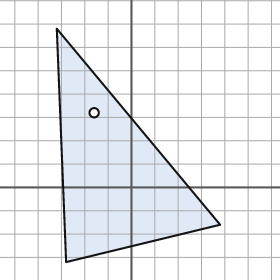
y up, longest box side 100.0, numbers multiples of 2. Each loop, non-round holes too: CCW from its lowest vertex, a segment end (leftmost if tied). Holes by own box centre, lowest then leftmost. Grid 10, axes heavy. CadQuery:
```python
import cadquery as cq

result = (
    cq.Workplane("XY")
    .moveTo(-28.0, -32.0)
    .lineTo(38.0, -16.0)
    .lineTo(-32.0, 68.0)
    .close()
    .moveTo(-16.0, 32.0)
    .circle(2.0)
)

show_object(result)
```